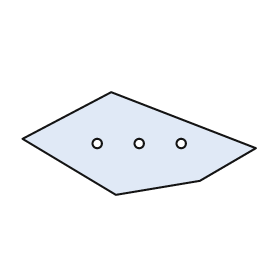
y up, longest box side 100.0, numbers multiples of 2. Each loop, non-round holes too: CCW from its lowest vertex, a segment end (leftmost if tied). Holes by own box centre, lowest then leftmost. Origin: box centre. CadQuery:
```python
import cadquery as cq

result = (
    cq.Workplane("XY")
    .moveTo(-10.0, -22.0)
    .lineTo(26.0, -16.0)
    .lineTo(50.0, -2.0)
    .lineTo(-12.0, 22.0)
    .lineTo(-50.0, 2.0)
    .close()
    .moveTo(-18.0, 0.0)
    .circle(2.0)
    .moveTo(0.0, 0.0)
    .circle(2.0)
    .moveTo(18.0, 0.0)
    .circle(2.0)
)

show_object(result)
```